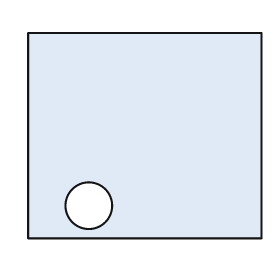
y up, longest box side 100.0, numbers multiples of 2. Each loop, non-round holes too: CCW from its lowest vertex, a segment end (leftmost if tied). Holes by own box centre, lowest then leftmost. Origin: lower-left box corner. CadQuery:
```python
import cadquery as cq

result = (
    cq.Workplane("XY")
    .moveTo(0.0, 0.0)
    .lineTo(100.0, 0.0)
    .lineTo(100.0, 88.0)
    .lineTo(0.0, 88.0)
    .close()
    .moveTo(26.0, 14.0)
    .circle(10.0)
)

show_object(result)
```